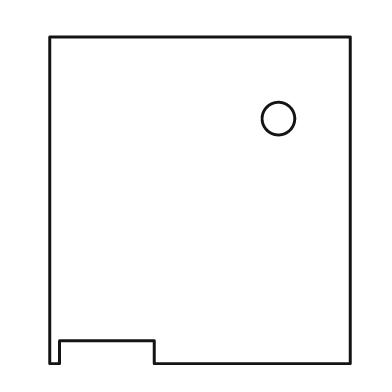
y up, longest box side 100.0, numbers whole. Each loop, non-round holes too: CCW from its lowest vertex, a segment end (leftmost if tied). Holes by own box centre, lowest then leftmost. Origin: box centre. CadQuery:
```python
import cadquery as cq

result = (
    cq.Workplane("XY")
    .moveTo(-46.0, -50.0)
    .lineTo(-43.0, -50.0)
    .lineTo(-43.0, -43.0)
    .lineTo(-14.0, -43.0)
    .lineTo(-14.0, -50.0)
    .lineTo(46.0, -50.0)
    .lineTo(46.0, 50.0)
    .lineTo(-46.0, 50.0)
    .close()
    .moveTo(24.0, 25.0)
    .circle(5.0)
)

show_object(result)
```